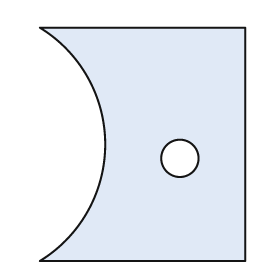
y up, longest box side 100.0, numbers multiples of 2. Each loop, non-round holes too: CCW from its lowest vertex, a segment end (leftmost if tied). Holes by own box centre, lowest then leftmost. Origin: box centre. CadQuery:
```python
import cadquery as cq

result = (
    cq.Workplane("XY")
    .moveTo(-44.0, -50.0)
    .lineTo(44.0, -50.0)
    .lineTo(44.0, 50.0)
    .lineTo(-44.0, 50.0)
    .threePointArc((-16.0, 0.0), (-44.0, -50.0))
    .close()
    .moveTo(16.0, -6.0)
    .circle(8.0)
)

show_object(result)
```